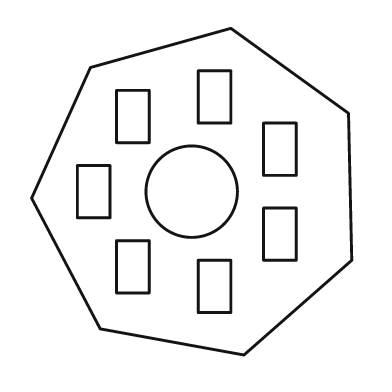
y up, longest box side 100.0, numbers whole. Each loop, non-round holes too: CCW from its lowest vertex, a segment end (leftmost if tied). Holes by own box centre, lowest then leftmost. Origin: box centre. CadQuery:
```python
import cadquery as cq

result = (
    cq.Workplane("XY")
    .moveTo(16.0, -50.0)
    .lineTo(49.0, -21.0)
    .lineTo(48.0, 24.0)
    .lineTo(12.0, 50.0)
    .lineTo(-31.0, 38.0)
    .lineTo(-49.0, -2.0)
    .lineTo(-28.0, -42.0)
    .close()
    .moveTo(2.0, -37.0)
    .lineTo(12.0, -37.0)
    .lineTo(12.0, -21.0)
    .lineTo(2.0, -21.0)
    .close()
    .moveTo(-23.0, -31.0)
    .lineTo(-13.0, -31.0)
    .lineTo(-13.0, -15.0)
    .lineTo(-23.0, -15.0)
    .close()
    .moveTo(22.0, -21.0)
    .lineTo(32.0, -21.0)
    .lineTo(32.0, -5.0)
    .lineTo(22.0, -5.0)
    .close()
    .moveTo(-35.0, -8.0)
    .lineTo(-25.0, -8.0)
    .lineTo(-25.0, 8.0)
    .lineTo(-35.0, 8.0)
    .close()
    .moveTo(0.0, 0.0)
    .circle(14.0)
    .moveTo(22.0, 5.0)
    .lineTo(32.0, 5.0)
    .lineTo(32.0, 21.0)
    .lineTo(22.0, 21.0)
    .close()
    .moveTo(-23.0, 15.0)
    .lineTo(-13.0, 15.0)
    .lineTo(-13.0, 31.0)
    .lineTo(-23.0, 31.0)
    .close()
    .moveTo(2.0, 21.0)
    .lineTo(12.0, 21.0)
    .lineTo(12.0, 37.0)
    .lineTo(2.0, 37.0)
    .close()
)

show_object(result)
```